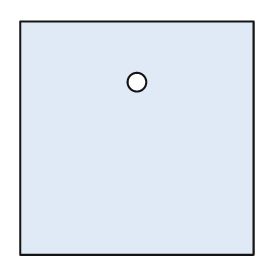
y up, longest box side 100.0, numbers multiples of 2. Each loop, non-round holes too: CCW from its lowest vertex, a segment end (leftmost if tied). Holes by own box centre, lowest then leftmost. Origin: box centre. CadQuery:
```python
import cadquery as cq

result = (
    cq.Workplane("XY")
    .moveTo(-50.0, -50.0)
    .lineTo(50.0, -50.0)
    .lineTo(50.0, 50.0)
    .lineTo(-50.0, 50.0)
    .close()
    .moveTo(0.0, 24.0)
    .circle(4.0)
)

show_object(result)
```